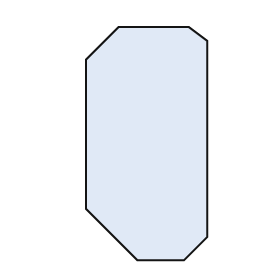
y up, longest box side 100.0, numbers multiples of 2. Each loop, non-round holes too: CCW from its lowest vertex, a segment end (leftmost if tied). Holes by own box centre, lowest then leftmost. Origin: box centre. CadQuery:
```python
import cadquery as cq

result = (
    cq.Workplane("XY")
    .moveTo(-4.0, -50.0)
    .lineTo(16.0, -50.0)
    .lineTo(26.0, -40.0)
    .lineTo(26.0, 44.0)
    .lineTo(18.0, 50.0)
    .lineTo(-12.0, 50.0)
    .lineTo(-26.0, 36.0)
    .lineTo(-26.0, -28.0)
    .close()
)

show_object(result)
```